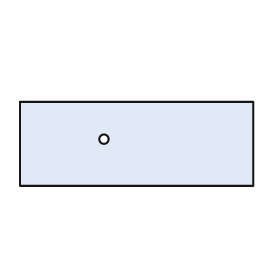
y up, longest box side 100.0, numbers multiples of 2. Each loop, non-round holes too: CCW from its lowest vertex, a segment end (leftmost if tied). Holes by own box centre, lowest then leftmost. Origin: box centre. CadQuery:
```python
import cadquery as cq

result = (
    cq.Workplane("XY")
    .moveTo(-50.0, -18.0)
    .lineTo(50.0, -18.0)
    .lineTo(50.0, 18.0)
    .lineTo(-50.0, 18.0)
    .close()
    .moveTo(-14.0, 2.0)
    .circle(2.0)
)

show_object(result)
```